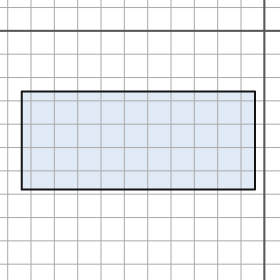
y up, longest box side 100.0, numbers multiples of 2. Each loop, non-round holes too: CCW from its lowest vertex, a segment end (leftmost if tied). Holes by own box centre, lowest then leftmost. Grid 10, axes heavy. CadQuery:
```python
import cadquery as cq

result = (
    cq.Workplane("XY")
    .moveTo(-104.0, -68.0)
    .lineTo(-4.0, -68.0)
    .lineTo(-4.0, -26.0)
    .lineTo(-104.0, -26.0)
    .close()
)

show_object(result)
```